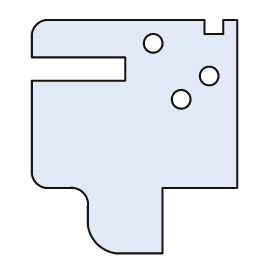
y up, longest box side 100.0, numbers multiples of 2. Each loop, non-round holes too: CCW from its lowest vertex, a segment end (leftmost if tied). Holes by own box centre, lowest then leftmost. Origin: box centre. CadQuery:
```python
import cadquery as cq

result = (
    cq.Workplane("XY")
    .moveTo(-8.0, -50.0)
    .lineTo(12.0, -50.0)
    .lineTo(12.0, -22.0)
    .lineTo(44.0, -22.0)
    .lineTo(44.0, 50.0)
    .lineTo(38.0, 50.0)
    .lineTo(38.0, 44.0)
    .lineTo(30.0, 44.0)
    .lineTo(30.0, 50.0)
    .lineTo(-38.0, 50.0)
    .threePointArc((-42.0, 48.0), (-44.0, 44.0))
    .lineTo(-44.0, 34.0)
    .lineTo(-4.0, 34.0)
    .lineTo(-4.0, 24.0)
    .lineTo(-44.0, 24.0)
    .lineTo(-44.0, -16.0)
    .threePointArc((-42.0, -20.0), (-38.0, -22.0))
    .lineTo(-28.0, -22.0)
    .threePointArc((-22.0, -24.0), (-20.0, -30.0))
    .lineTo(-20.0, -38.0)
    .threePointArc((-16.0, -46.0), (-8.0, -50.0))
    .close()
    .moveTo(20.0, 16.0)
    .circle(4.0)
    .moveTo(32.0, 26.0)
    .circle(4.0)
    .moveTo(8.0, 40.0)
    .circle(4.0)
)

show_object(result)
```